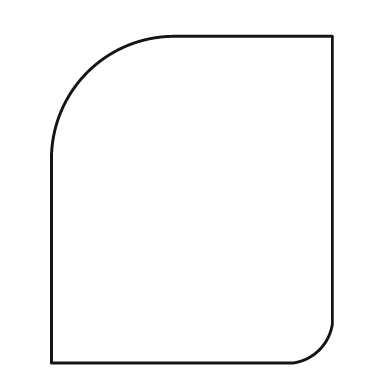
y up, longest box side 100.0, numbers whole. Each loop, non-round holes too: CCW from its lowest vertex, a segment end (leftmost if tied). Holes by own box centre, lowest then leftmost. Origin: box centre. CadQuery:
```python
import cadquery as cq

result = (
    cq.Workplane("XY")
    .moveTo(-43.0, -50.0)
    .lineTo(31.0, -50.0)
    .threePointArc((39.0, -46.0), (43.0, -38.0))
    .lineTo(43.0, 50.0)
    .lineTo(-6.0, 50.0)
    .threePointArc((-32.0, 39.0), (-43.0, 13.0))
    .close()
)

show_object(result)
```